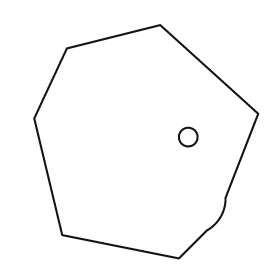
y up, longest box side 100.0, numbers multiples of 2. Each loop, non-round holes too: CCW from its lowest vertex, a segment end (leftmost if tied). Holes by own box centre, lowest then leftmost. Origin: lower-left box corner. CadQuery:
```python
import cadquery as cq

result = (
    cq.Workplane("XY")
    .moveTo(62.0, 0.0)
    .lineTo(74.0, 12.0)
    .threePointArc((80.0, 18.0), (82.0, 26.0))
    .lineTo(96.0, 62.0)
    .lineTo(54.0, 100.0)
    .lineTo(14.0, 90.0)
    .lineTo(0.0, 60.0)
    .lineTo(12.0, 10.0)
    .close()
    .moveTo(66.0, 52.0)
    .circle(4.0)
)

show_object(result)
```